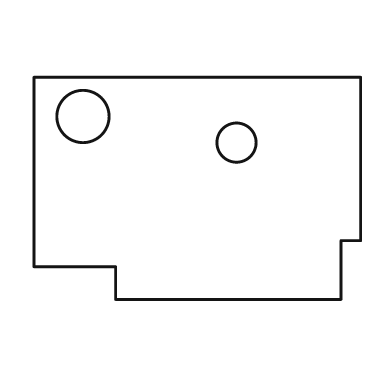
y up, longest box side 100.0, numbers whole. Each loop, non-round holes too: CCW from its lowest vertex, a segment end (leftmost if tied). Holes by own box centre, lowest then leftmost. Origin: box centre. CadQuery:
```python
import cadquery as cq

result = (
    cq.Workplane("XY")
    .moveTo(-25.0, -34.0)
    .lineTo(44.0, -34.0)
    .lineTo(44.0, -16.0)
    .lineTo(50.0, -16.0)
    .lineTo(50.0, 34.0)
    .lineTo(-50.0, 34.0)
    .lineTo(-50.0, -24.0)
    .lineTo(-25.0, -24.0)
    .close()
    .moveTo(12.0, 14.0)
    .circle(6.0)
    .moveTo(-35.0, 22.0)
    .circle(8.0)
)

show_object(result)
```